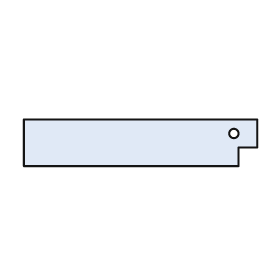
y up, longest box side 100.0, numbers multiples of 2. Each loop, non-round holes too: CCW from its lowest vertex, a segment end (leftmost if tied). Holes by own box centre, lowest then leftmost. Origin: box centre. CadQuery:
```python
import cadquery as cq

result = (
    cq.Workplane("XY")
    .moveTo(-50.0, -10.0)
    .lineTo(42.0, -10.0)
    .lineTo(42.0, -2.0)
    .lineTo(50.0, -2.0)
    .lineTo(50.0, 10.0)
    .lineTo(-50.0, 10.0)
    .close()
    .moveTo(40.0, 4.0)
    .circle(2.0)
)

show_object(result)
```